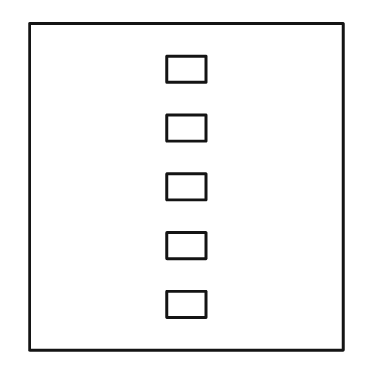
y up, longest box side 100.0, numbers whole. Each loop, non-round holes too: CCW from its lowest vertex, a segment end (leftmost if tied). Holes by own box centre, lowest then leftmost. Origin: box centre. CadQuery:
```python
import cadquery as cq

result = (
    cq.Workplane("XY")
    .moveTo(-48.0, -50.0)
    .lineTo(48.0, -50.0)
    .lineTo(48.0, 50.0)
    .lineTo(-48.0, 50.0)
    .close()
    .moveTo(-6.0, -40.0)
    .lineTo(6.0, -40.0)
    .lineTo(6.0, -32.0)
    .lineTo(-6.0, -32.0)
    .close()
    .moveTo(-6.0, -22.0)
    .lineTo(6.0, -22.0)
    .lineTo(6.0, -14.0)
    .lineTo(-6.0, -14.0)
    .close()
    .moveTo(-6.0, -4.0)
    .lineTo(6.0, -4.0)
    .lineTo(6.0, 4.0)
    .lineTo(-6.0, 4.0)
    .close()
    .moveTo(-6.0, 14.0)
    .lineTo(6.0, 14.0)
    .lineTo(6.0, 22.0)
    .lineTo(-6.0, 22.0)
    .close()
    .moveTo(-6.0, 32.0)
    .lineTo(6.0, 32.0)
    .lineTo(6.0, 40.0)
    .lineTo(-6.0, 40.0)
    .close()
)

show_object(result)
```